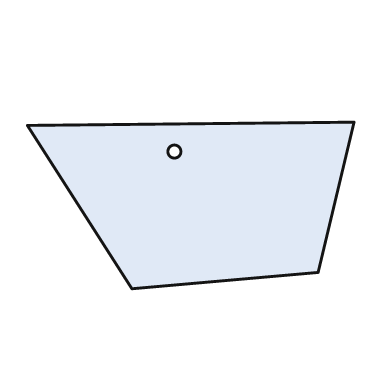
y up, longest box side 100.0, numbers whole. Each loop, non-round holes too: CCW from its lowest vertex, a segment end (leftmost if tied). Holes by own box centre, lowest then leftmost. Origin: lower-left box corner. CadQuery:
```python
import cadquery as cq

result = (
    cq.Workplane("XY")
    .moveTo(32.0, 0.0)
    .lineTo(89.0, 5.0)
    .lineTo(100.0, 51.0)
    .lineTo(0.0, 50.0)
    .close()
    .moveTo(45.0, 42.0)
    .circle(2.0)
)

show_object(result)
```